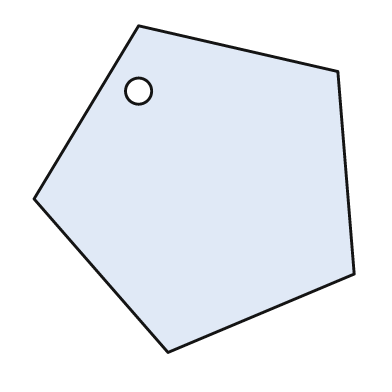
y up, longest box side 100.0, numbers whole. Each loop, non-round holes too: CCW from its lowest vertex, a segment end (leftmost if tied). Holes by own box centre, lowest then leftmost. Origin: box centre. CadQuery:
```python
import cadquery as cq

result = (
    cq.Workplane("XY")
    .moveTo(-8.0, -50.0)
    .lineTo(49.0, -26.0)
    .lineTo(44.0, 36.0)
    .lineTo(-17.0, 50.0)
    .lineTo(-49.0, -3.0)
    .close()
    .moveTo(-17.0, 30.0)
    .circle(4.0)
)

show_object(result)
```